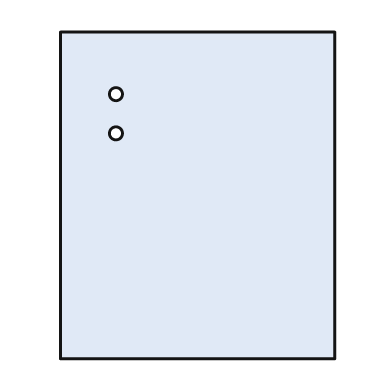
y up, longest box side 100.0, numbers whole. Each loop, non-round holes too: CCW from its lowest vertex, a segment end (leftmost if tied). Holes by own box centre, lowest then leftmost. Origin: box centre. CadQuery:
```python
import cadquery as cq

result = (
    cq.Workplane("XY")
    .moveTo(-42.0, -50.0)
    .lineTo(42.0, -50.0)
    .lineTo(42.0, 50.0)
    .lineTo(-42.0, 50.0)
    .close()
    .moveTo(-25.0, 19.0)
    .circle(2.0)
    .moveTo(-25.0, 31.0)
    .circle(2.0)
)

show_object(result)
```